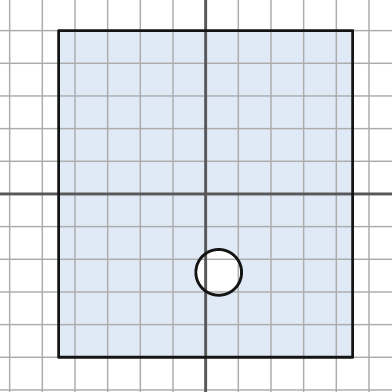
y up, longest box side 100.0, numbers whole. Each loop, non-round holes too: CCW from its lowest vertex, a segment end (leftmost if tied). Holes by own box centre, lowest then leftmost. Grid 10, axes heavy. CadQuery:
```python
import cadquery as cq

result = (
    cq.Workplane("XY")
    .moveTo(-45.0, -50.0)
    .lineTo(45.0, -50.0)
    .lineTo(45.0, 50.0)
    .lineTo(-45.0, 50.0)
    .close()
    .moveTo(4.0, -24.0)
    .circle(7.0)
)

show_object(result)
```